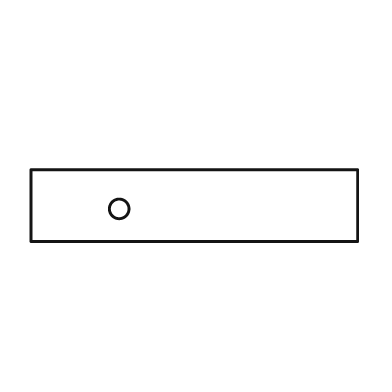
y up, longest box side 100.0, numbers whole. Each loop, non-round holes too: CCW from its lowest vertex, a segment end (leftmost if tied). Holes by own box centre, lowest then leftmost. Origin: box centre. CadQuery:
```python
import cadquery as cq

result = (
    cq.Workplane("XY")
    .moveTo(-50.0, -11.0)
    .lineTo(50.0, -11.0)
    .lineTo(50.0, 11.0)
    .lineTo(-50.0, 11.0)
    .close()
    .moveTo(-23.0, -1.0)
    .circle(3.0)
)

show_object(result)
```